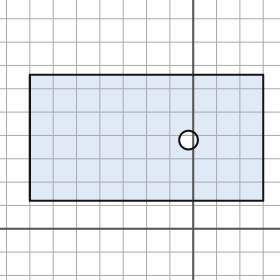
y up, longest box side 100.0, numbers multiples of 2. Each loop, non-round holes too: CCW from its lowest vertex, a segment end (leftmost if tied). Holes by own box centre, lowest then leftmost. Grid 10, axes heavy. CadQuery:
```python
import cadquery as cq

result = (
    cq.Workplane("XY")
    .moveTo(-70.0, 12.0)
    .lineTo(30.0, 12.0)
    .lineTo(30.0, 66.0)
    .lineTo(-70.0, 66.0)
    .close()
    .moveTo(-2.0, 38.0)
    .circle(4.0)
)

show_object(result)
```